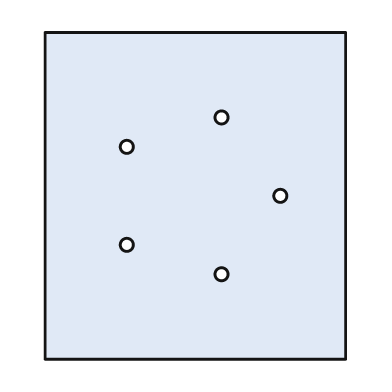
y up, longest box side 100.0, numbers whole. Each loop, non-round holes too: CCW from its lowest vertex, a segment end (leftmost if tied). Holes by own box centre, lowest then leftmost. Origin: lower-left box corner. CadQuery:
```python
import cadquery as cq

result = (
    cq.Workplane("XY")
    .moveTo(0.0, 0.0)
    .lineTo(92.0, 0.0)
    .lineTo(92.0, 100.0)
    .lineTo(0.0, 100.0)
    .close()
    .moveTo(54.0, 26.0)
    .circle(2.0)
    .moveTo(25.0, 35.0)
    .circle(2.0)
    .moveTo(72.0, 50.0)
    .circle(2.0)
    .moveTo(25.0, 65.0)
    .circle(2.0)
    .moveTo(54.0, 74.0)
    .circle(2.0)
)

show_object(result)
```